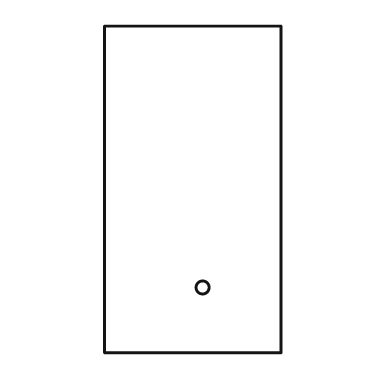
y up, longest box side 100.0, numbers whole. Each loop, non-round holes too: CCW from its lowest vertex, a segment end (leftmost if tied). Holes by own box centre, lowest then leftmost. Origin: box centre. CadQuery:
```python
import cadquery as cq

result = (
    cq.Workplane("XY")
    .moveTo(-27.0, -50.0)
    .lineTo(27.0, -50.0)
    .lineTo(27.0, 50.0)
    .lineTo(-27.0, 50.0)
    .close()
    .moveTo(3.0, -30.0)
    .circle(2.0)
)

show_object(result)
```